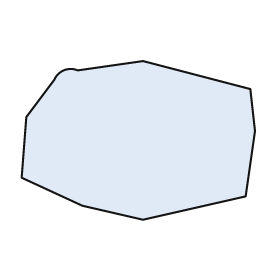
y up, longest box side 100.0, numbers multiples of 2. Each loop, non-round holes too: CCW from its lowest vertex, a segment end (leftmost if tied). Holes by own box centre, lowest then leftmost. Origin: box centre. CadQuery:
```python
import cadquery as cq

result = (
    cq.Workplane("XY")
    .moveTo(2.0, -34.0)
    .lineTo(46.0, -24.0)
    .lineTo(50.0, 4.0)
    .lineTo(48.0, 22.0)
    .lineTo(2.0, 34.0)
    .lineTo(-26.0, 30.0)
    .threePointArc((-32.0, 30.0), (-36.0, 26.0))
    .lineTo(-48.0, 10.0)
    .lineTo(-50.0, -16.0)
    .lineTo(-24.0, -28.0)
    .close()
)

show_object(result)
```